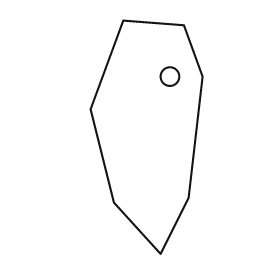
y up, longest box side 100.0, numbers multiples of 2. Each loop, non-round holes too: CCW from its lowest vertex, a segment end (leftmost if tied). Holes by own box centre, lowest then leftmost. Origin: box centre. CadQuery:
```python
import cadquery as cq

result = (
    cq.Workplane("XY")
    .moveTo(6.0, -50.0)
    .lineTo(18.0, -26.0)
    .lineTo(24.0, 26.0)
    .lineTo(16.0, 48.0)
    .lineTo(-10.0, 50.0)
    .lineTo(-24.0, 12.0)
    .lineTo(-14.0, -28.0)
    .close()
    .moveTo(10.0, 26.0)
    .circle(4.0)
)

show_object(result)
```